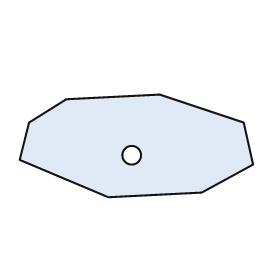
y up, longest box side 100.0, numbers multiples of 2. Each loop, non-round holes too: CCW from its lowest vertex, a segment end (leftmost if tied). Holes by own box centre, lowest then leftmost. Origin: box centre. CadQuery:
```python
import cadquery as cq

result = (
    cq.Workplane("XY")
    .moveTo(-12.0, -22.0)
    .lineTo(28.0, -20.0)
    .lineTo(50.0, -8.0)
    .lineTo(46.0, 10.0)
    .lineTo(10.0, 22.0)
    .lineTo(-30.0, 20.0)
    .lineTo(-46.0, 10.0)
    .lineTo(-50.0, -6.0)
    .close()
    .moveTo(-2.0, -4.0)
    .circle(4.0)
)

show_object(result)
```